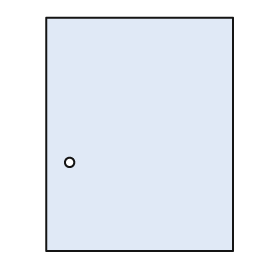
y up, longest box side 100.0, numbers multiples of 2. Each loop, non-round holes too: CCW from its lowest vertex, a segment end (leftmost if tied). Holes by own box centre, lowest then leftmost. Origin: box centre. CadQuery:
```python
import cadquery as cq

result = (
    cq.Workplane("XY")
    .moveTo(-40.0, -50.0)
    .lineTo(40.0, -50.0)
    .lineTo(40.0, 50.0)
    .lineTo(-40.0, 50.0)
    .close()
    .moveTo(-30.0, -12.0)
    .circle(2.0)
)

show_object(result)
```